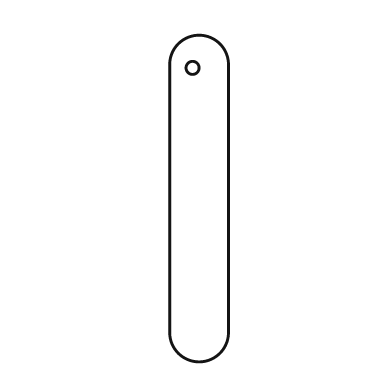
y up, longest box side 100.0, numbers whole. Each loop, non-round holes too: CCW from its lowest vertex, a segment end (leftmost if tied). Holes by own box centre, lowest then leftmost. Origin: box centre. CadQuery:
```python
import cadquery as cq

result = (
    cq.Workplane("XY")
    .moveTo(-9.0, -41.0)
    .threePointArc((0.0, -50.0), (9.0, -41.0))
    .lineTo(9.0, 41.0)
    .threePointArc((0.0, 50.0), (-9.0, 41.0))
    .close()
    .moveTo(-2.0, 40.0)
    .circle(2.0)
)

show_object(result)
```